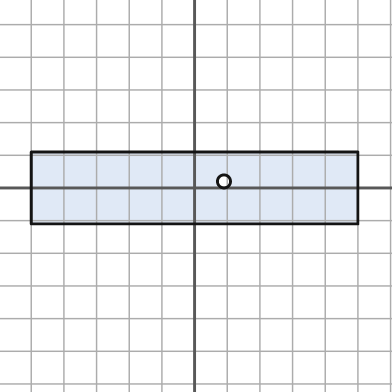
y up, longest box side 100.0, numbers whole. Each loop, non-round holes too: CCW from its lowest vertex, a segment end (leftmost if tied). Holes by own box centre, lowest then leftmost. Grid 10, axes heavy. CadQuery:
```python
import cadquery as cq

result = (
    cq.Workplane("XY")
    .moveTo(-50.0, -11.0)
    .lineTo(50.0, -11.0)
    .lineTo(50.0, 11.0)
    .lineTo(-50.0, 11.0)
    .close()
    .moveTo(9.0, 2.0)
    .circle(2.0)
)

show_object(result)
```